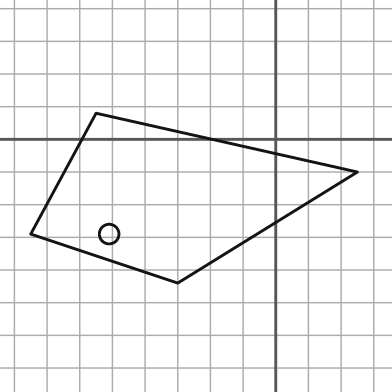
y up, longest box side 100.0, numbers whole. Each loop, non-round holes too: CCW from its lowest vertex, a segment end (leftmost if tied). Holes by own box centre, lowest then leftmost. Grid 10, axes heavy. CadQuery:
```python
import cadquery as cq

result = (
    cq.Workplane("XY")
    .moveTo(-30.0, -44.0)
    .lineTo(25.0, -10.0)
    .lineTo(-55.0, 8.0)
    .lineTo(-75.0, -29.0)
    .close()
    .moveTo(-51.0, -29.0)
    .circle(3.0)
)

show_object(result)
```